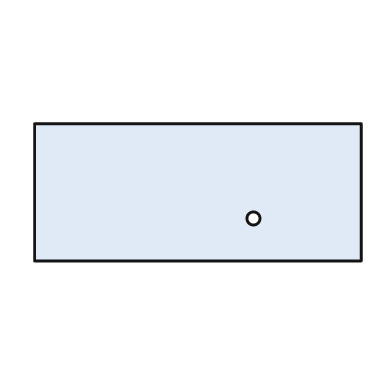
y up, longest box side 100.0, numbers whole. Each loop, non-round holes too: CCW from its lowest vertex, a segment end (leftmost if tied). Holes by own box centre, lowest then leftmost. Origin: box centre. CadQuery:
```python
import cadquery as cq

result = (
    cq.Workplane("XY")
    .moveTo(-50.0, -21.0)
    .lineTo(50.0, -21.0)
    .lineTo(50.0, 21.0)
    .lineTo(-50.0, 21.0)
    .close()
    .moveTo(17.0, -8.0)
    .circle(2.0)
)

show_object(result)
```